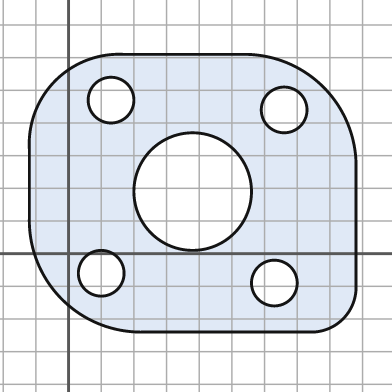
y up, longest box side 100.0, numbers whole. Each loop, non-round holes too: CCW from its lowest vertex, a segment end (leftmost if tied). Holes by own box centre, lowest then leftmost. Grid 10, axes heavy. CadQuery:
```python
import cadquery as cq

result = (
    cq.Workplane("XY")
    .moveTo(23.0, -24.0)
    .lineTo(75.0, -24.0)
    .threePointArc((84.0, -20.0), (88.0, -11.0))
    .lineTo(88.0, 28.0)
    .threePointArc((78.0, 51.0), (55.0, 61.0))
    .lineTo(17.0, 61.0)
    .threePointArc((-4.0, 53.0), (-12.0, 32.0))
    .lineTo(-12.0, 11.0)
    .threePointArc((-2.0, -14.0), (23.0, -24.0))
    .close()
    .moveTo(63.0, -9.0)
    .circle(7.0)
    .moveTo(10.0, -6.0)
    .circle(7.0)
    .moveTo(38.0, 19.0)
    .circle(18.0)
    .moveTo(66.0, 44.0)
    .circle(7.0)
    .moveTo(13.0, 47.0)
    .circle(7.0)
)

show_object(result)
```